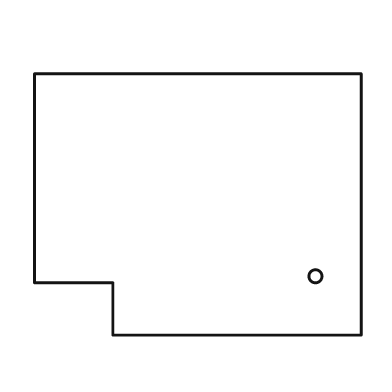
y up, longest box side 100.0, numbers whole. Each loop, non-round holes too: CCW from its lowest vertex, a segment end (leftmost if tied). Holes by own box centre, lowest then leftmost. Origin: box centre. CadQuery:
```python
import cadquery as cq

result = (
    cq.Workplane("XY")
    .moveTo(-26.0, -40.0)
    .lineTo(50.0, -40.0)
    .lineTo(50.0, 40.0)
    .lineTo(-50.0, 40.0)
    .lineTo(-50.0, -24.0)
    .lineTo(-26.0, -24.0)
    .close()
    .moveTo(36.0, -22.0)
    .circle(2.0)
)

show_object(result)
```